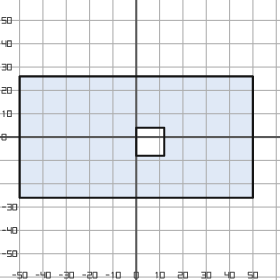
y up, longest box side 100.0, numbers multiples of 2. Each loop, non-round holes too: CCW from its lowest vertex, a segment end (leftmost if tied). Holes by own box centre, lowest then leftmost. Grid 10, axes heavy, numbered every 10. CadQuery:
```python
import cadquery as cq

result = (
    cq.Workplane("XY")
    .moveTo(-50.0, -26.0)
    .lineTo(50.0, -26.0)
    .lineTo(50.0, 26.0)
    .lineTo(-50.0, 26.0)
    .close()
    .moveTo(0.0, -8.0)
    .lineTo(12.0, -8.0)
    .lineTo(12.0, 4.0)
    .lineTo(0.0, 4.0)
    .close()
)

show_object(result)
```